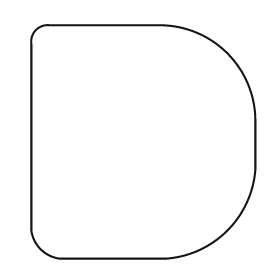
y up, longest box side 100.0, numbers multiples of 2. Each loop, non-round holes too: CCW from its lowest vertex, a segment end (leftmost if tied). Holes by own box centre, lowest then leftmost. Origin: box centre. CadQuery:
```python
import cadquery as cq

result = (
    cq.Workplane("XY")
    .moveTo(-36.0, -50.0)
    .lineTo(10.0, -50.0)
    .threePointArc((36.0, -38.0), (48.0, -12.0))
    .lineTo(48.0, 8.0)
    .threePointArc((36.0, 38.0), (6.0, 50.0))
    .lineTo(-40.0, 50.0)
    .threePointArc((-46.0, 48.0), (-48.0, 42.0))
    .lineTo(-48.0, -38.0)
    .threePointArc((-44.0, -46.0), (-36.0, -50.0))
    .close()
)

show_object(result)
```